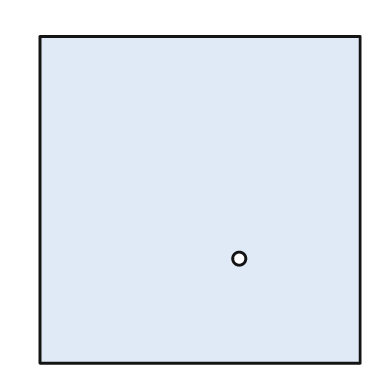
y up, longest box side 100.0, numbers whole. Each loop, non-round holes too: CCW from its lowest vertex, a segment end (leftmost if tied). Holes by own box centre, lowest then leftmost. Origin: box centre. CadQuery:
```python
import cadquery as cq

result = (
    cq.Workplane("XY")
    .moveTo(-49.0, -50.0)
    .lineTo(49.0, -50.0)
    .lineTo(49.0, 50.0)
    .lineTo(-49.0, 50.0)
    .close()
    .moveTo(12.0, -18.0)
    .circle(2.0)
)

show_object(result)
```